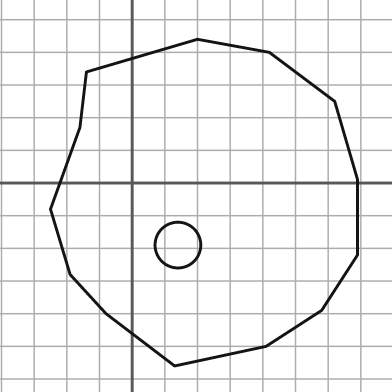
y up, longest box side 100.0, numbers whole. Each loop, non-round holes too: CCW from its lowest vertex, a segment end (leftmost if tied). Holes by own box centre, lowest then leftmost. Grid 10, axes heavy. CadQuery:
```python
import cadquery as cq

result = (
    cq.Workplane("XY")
    .moveTo(13.0, -56.0)
    .lineTo(41.0, -50.0)
    .lineTo(58.0, -39.0)
    .lineTo(69.0, -22.0)
    .lineTo(69.0, 1.0)
    .lineTo(62.0, 25.0)
    .lineTo(42.0, 40.0)
    .lineTo(20.0, 44.0)
    .lineTo(-14.0, 34.0)
    .lineTo(-16.0, 17.0)
    .lineTo(-25.0, -8.0)
    .lineTo(-19.0, -28.0)
    .lineTo(-8.0, -40.0)
    .close()
    .moveTo(14.0, -19.0)
    .circle(7.0)
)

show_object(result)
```